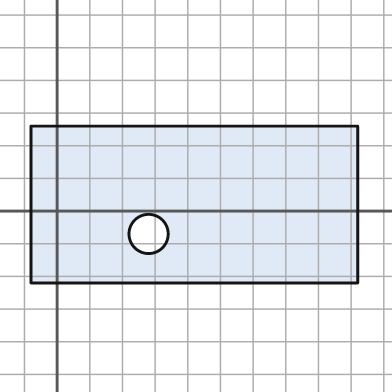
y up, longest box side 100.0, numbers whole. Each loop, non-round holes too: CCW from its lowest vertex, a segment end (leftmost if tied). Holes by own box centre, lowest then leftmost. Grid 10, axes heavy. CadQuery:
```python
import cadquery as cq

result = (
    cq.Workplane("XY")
    .moveTo(-8.0, -22.0)
    .lineTo(92.0, -22.0)
    .lineTo(92.0, 26.0)
    .lineTo(-8.0, 26.0)
    .close()
    .moveTo(28.0, -7.0)
    .circle(6.0)
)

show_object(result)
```